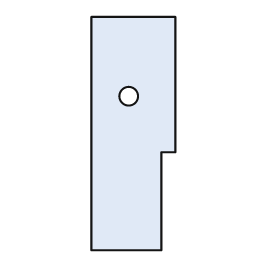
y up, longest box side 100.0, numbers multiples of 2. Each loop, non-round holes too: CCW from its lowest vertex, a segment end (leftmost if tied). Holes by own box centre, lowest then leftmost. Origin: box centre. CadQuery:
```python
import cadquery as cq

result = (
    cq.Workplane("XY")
    .moveTo(-18.0, -50.0)
    .lineTo(12.0, -50.0)
    .lineTo(12.0, -8.0)
    .lineTo(18.0, -8.0)
    .lineTo(18.0, 50.0)
    .lineTo(-18.0, 50.0)
    .close()
    .moveTo(-2.0, 16.0)
    .circle(4.0)
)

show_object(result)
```